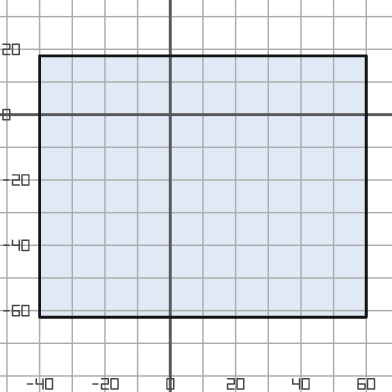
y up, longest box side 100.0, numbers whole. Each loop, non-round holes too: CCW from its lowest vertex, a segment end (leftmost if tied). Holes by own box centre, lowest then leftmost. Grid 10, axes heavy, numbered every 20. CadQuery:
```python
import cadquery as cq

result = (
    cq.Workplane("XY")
    .moveTo(-40.0, -62.0)
    .lineTo(60.0, -62.0)
    .lineTo(60.0, 18.0)
    .lineTo(-40.0, 18.0)
    .close()
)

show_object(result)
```